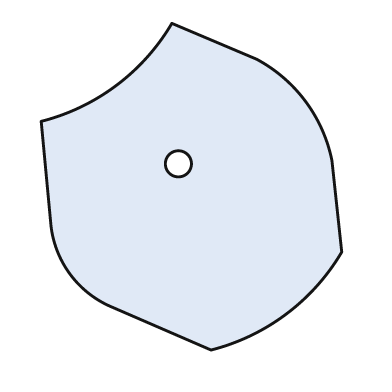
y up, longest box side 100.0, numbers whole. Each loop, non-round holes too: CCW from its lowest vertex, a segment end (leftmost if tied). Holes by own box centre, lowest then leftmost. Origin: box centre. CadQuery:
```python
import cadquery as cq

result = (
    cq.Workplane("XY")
    .moveTo(6.0, -50.0)
    .threePointArc((29.0, -39.0), (46.0, -20.0))
    .lineTo(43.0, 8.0)
    .threePointArc((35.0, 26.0), (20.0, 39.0))
    .lineTo(-6.0, 50.0)
    .threePointArc((-23.0, 31.0), (-46.0, 20.0))
    .lineTo(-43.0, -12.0)
    .threePointArc((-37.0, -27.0), (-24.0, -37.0))
    .close()
    .moveTo(-4.0, 7.0)
    .circle(4.0)
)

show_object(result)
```